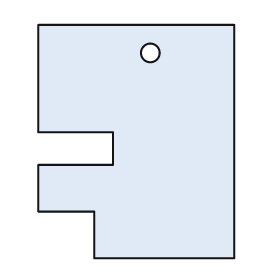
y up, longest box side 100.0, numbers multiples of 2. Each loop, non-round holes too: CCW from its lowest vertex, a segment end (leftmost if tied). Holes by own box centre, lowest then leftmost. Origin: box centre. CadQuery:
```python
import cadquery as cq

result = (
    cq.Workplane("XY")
    .moveTo(-18.0, -50.0)
    .lineTo(42.0, -50.0)
    .lineTo(42.0, 50.0)
    .lineTo(-42.0, 50.0)
    .lineTo(-42.0, 4.0)
    .lineTo(-10.0, 4.0)
    .lineTo(-10.0, -10.0)
    .lineTo(-42.0, -10.0)
    .lineTo(-42.0, -30.0)
    .lineTo(-18.0, -30.0)
    .close()
    .moveTo(6.0, 38.0)
    .circle(4.0)
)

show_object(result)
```